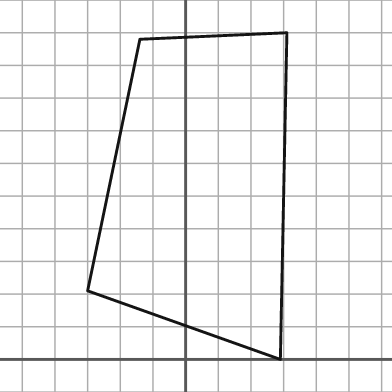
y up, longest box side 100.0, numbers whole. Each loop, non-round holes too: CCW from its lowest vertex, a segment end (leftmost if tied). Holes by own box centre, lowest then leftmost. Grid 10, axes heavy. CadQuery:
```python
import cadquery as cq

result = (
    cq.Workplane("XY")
    .moveTo(29.0, 0.0)
    .lineTo(31.0, 100.0)
    .lineTo(-14.0, 98.0)
    .lineTo(-30.0, 21.0)
    .close()
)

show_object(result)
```